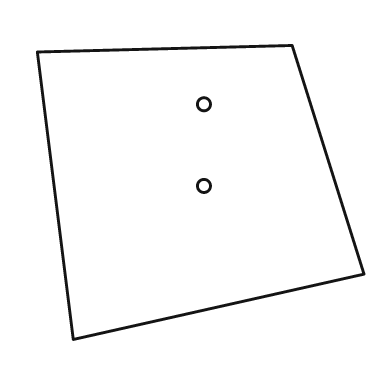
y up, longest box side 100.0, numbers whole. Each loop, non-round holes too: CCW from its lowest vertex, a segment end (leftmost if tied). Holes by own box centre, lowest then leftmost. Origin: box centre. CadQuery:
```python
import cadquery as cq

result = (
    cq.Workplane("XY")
    .moveTo(-39.0, -45.0)
    .lineTo(50.0, -25.0)
    .lineTo(28.0, 45.0)
    .lineTo(-50.0, 43.0)
    .close()
    .moveTo(1.0, 2.0)
    .circle(2.0)
    .moveTo(1.0, 27.0)
    .circle(2.0)
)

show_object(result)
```